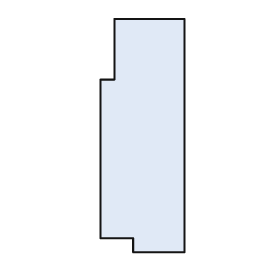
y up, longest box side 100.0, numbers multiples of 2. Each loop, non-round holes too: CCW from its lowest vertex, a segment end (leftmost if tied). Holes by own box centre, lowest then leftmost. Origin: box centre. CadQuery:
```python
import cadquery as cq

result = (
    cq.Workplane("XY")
    .moveTo(-4.0, -50.0)
    .lineTo(18.0, -50.0)
    .lineTo(18.0, 50.0)
    .lineTo(-12.0, 50.0)
    .lineTo(-12.0, 24.0)
    .lineTo(-18.0, 24.0)
    .lineTo(-18.0, -44.0)
    .lineTo(-4.0, -44.0)
    .close()
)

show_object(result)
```